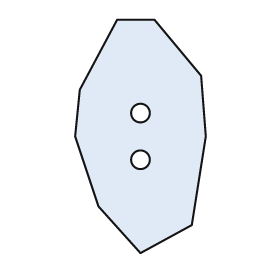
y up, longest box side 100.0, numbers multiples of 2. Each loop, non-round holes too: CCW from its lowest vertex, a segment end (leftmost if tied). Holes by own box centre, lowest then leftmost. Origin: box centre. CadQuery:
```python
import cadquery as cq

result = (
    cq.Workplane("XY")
    .moveTo(0.0, -50.0)
    .lineTo(22.0, -38.0)
    .lineTo(28.0, 0.0)
    .lineTo(26.0, 26.0)
    .lineTo(6.0, 50.0)
    .lineTo(-10.0, 50.0)
    .lineTo(-26.0, 20.0)
    .lineTo(-28.0, 0.0)
    .lineTo(-18.0, -30.0)
    .close()
    .moveTo(0.0, -10.0)
    .circle(4.0)
    .moveTo(0.0, 10.0)
    .circle(4.0)
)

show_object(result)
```